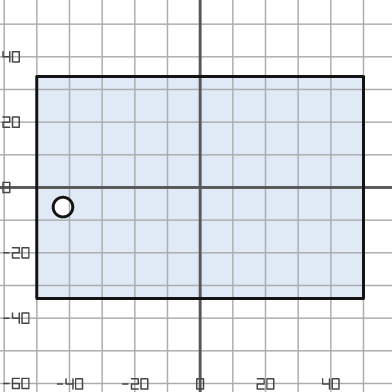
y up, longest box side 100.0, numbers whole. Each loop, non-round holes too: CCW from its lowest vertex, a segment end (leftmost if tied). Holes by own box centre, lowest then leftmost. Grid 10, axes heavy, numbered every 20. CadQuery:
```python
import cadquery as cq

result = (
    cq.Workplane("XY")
    .moveTo(-50.0, -34.0)
    .lineTo(50.0, -34.0)
    .lineTo(50.0, 34.0)
    .lineTo(-50.0, 34.0)
    .close()
    .moveTo(-42.0, -6.0)
    .circle(3.0)
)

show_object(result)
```